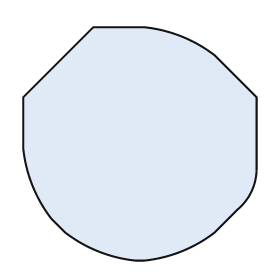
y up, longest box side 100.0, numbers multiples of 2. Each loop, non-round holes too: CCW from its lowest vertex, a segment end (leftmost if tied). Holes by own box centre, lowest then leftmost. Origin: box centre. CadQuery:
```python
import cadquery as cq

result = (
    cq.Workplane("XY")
    .moveTo(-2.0, -50.0)
    .lineTo(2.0, -50.0)
    .threePointArc((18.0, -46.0), (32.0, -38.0))
    .lineTo(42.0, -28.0)
    .threePointArc((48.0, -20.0), (50.0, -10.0))
    .lineTo(50.0, 20.0)
    .lineTo(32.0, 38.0)
    .threePointArc((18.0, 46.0), (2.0, 50.0))
    .lineTo(-20.0, 50.0)
    .lineTo(-50.0, 20.0)
    .lineTo(-50.0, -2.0)
    .threePointArc((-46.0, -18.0), (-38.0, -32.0))
    .lineTo(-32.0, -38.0)
    .threePointArc((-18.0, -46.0), (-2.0, -50.0))
    .close()
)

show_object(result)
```